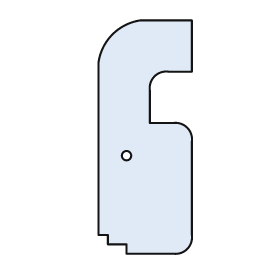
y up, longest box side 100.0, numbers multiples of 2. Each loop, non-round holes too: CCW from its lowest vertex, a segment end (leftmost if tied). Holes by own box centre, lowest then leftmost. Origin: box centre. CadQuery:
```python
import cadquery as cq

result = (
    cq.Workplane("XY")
    .moveTo(-8.0, -50.0)
    .lineTo(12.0, -50.0)
    .threePointArc((18.0, -48.0), (20.0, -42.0))
    .lineTo(20.0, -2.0)
    .threePointArc((18.0, 4.0), (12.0, 6.0))
    .lineTo(2.0, 6.0)
    .lineTo(2.0, 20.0)
    .threePointArc((4.0, 26.0), (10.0, 28.0))
    .lineTo(20.0, 28.0)
    .lineTo(20.0, 50.0)
    .lineTo(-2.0, 50.0)
    .threePointArc((-14.0, 44.0), (-20.0, 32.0))
    .lineTo(-20.0, -42.0)
    .lineTo(-16.0, -42.0)
    .lineTo(-16.0, -46.0)
    .lineTo(-8.0, -46.0)
    .close()
    .moveTo(-8.0, -8.0)
    .circle(2.0)
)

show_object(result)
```